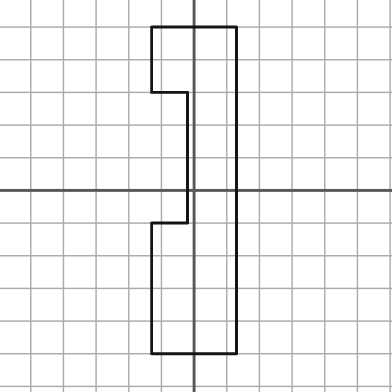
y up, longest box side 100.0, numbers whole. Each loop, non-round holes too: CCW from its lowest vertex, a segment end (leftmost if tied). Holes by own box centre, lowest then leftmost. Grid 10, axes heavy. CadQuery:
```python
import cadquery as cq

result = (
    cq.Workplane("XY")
    .moveTo(-13.0, -50.0)
    .lineTo(13.0, -50.0)
    .lineTo(13.0, 50.0)
    .lineTo(-13.0, 50.0)
    .lineTo(-13.0, 30.0)
    .lineTo(-2.0, 30.0)
    .lineTo(-2.0, -10.0)
    .lineTo(-13.0, -10.0)
    .close()
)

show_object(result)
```